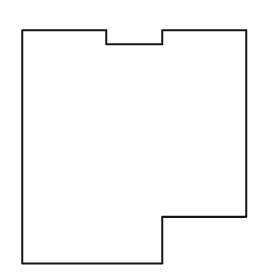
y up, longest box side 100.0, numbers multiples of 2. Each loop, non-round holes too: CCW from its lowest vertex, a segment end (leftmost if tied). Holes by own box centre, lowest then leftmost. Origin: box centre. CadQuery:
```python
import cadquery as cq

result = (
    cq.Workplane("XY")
    .moveTo(-48.0, -50.0)
    .lineTo(12.0, -50.0)
    .lineTo(12.0, -30.0)
    .lineTo(48.0, -30.0)
    .lineTo(48.0, 50.0)
    .lineTo(12.0, 50.0)
    .lineTo(12.0, 44.0)
    .lineTo(-12.0, 44.0)
    .lineTo(-12.0, 50.0)
    .lineTo(-48.0, 50.0)
    .close()
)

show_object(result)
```